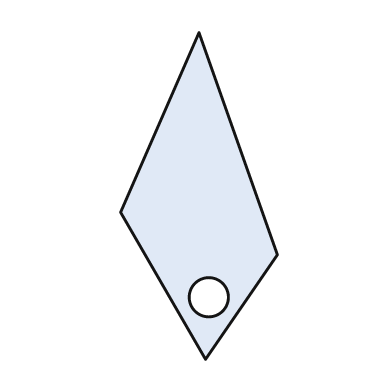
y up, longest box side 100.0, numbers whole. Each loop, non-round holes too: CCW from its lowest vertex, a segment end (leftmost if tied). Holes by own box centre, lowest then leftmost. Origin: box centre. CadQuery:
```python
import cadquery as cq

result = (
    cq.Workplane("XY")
    .moveTo(2.0, -50.0)
    .lineTo(24.0, -18.0)
    .lineTo(0.0, 50.0)
    .lineTo(-24.0, -5.0)
    .close()
    .moveTo(3.0, -31.0)
    .circle(6.0)
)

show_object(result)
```